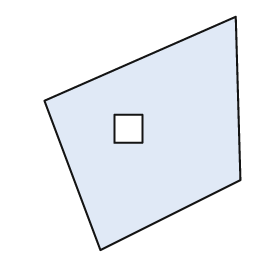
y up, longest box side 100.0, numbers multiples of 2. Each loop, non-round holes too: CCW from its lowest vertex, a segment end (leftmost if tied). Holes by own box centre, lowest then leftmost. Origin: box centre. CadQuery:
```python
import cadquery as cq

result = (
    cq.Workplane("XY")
    .moveTo(-18.0, -50.0)
    .lineTo(42.0, -20.0)
    .lineTo(40.0, 50.0)
    .lineTo(-42.0, 14.0)
    .close()
    .moveTo(-12.0, -4.0)
    .lineTo(0.0, -4.0)
    .lineTo(0.0, 8.0)
    .lineTo(-12.0, 8.0)
    .close()
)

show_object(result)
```